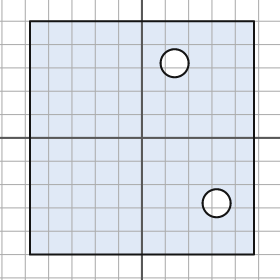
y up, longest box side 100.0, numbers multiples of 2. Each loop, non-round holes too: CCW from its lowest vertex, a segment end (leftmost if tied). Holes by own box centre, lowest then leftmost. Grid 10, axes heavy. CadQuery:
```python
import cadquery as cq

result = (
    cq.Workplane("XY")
    .moveTo(-48.0, -50.0)
    .lineTo(48.0, -50.0)
    .lineTo(48.0, 50.0)
    .lineTo(-48.0, 50.0)
    .close()
    .moveTo(32.0, -28.0)
    .circle(6.0)
    .moveTo(14.0, 32.0)
    .circle(6.0)
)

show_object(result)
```